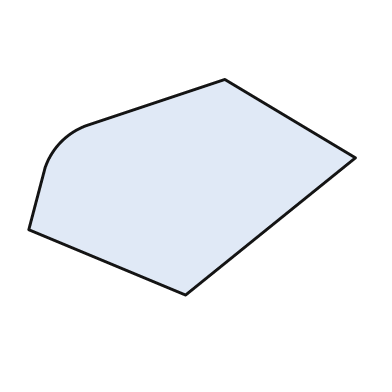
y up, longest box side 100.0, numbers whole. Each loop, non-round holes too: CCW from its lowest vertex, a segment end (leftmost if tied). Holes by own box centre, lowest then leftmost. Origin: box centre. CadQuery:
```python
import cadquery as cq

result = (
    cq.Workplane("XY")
    .moveTo(-2.0, -33.0)
    .lineTo(50.0, 9.0)
    .lineTo(10.0, 33.0)
    .lineTo(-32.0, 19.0)
    .threePointArc((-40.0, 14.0), (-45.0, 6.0))
    .lineTo(-50.0, -13.0)
    .close()
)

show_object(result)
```